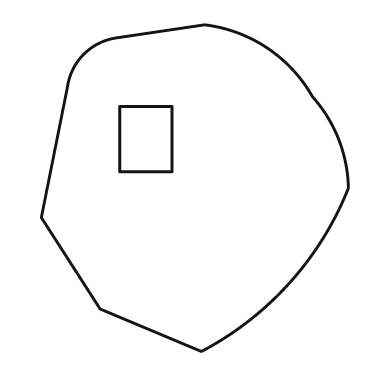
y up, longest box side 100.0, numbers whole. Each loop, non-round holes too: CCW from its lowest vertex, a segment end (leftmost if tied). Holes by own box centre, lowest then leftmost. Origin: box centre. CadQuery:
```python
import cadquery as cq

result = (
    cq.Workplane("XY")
    .moveTo(2.0, -50.0)
    .threePointArc((29.0, -29.0), (47.0, 0.0))
    .threePointArc((44.0, 15.0), (36.0, 28.0))
    .threePointArc((22.0, 43.0), (3.0, 50.0))
    .lineTo(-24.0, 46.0)
    .threePointArc((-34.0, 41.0), (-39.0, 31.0))
    .lineTo(-47.0, -9.0)
    .lineTo(-29.0, -37.0)
    .close()
    .moveTo(-23.0, 5.0)
    .lineTo(-7.0, 5.0)
    .lineTo(-7.0, 25.0)
    .lineTo(-23.0, 25.0)
    .close()
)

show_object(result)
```